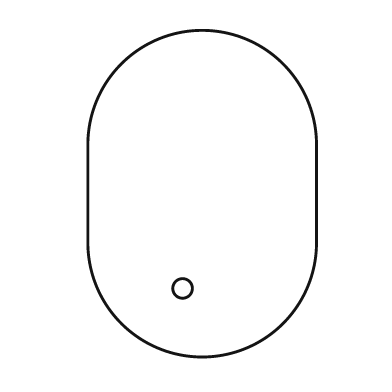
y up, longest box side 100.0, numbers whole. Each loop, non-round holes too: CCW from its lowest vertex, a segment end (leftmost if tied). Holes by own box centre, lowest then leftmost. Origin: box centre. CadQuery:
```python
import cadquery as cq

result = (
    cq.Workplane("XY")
    .moveTo(-35.0, -15.0)
    .threePointArc((0.0, -50.0), (35.0, -15.0))
    .lineTo(35.0, 15.0)
    .threePointArc((0.0, 50.0), (-35.0, 15.0))
    .close()
    .moveTo(-6.0, -29.0)
    .circle(3.0)
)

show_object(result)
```